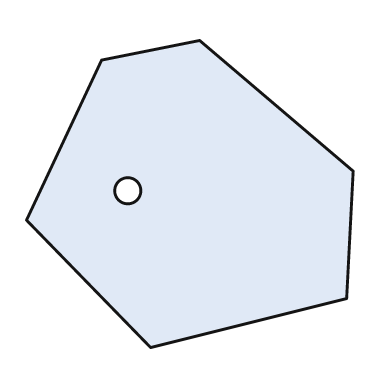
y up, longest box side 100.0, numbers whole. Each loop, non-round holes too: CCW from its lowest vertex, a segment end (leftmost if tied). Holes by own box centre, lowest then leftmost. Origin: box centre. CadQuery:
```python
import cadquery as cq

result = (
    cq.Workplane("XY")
    .moveTo(-12.0, -47.0)
    .lineTo(48.0, -32.0)
    .lineTo(50.0, 7.0)
    .lineTo(3.0, 47.0)
    .lineTo(-27.0, 41.0)
    .lineTo(-50.0, -8.0)
    .close()
    .moveTo(-19.0, 1.0)
    .circle(4.0)
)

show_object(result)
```